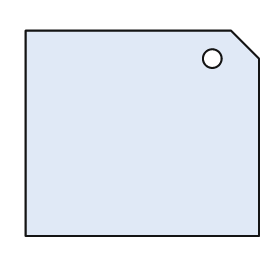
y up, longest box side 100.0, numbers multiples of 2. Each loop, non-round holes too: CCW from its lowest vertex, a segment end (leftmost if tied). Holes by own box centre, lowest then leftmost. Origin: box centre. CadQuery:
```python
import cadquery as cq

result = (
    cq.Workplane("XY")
    .moveTo(-50.0, -44.0)
    .lineTo(50.0, -44.0)
    .lineTo(50.0, 32.0)
    .lineTo(38.0, 44.0)
    .lineTo(-50.0, 44.0)
    .close()
    .moveTo(30.0, 32.0)
    .circle(4.0)
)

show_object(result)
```